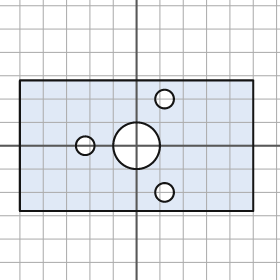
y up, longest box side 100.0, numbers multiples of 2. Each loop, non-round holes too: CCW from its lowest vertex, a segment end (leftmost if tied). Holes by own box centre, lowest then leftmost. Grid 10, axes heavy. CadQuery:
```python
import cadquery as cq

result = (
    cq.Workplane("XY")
    .moveTo(-50.0, -28.0)
    .lineTo(50.0, -28.0)
    .lineTo(50.0, 28.0)
    .lineTo(-50.0, 28.0)
    .close()
    .moveTo(12.0, -20.0)
    .circle(4.0)
    .moveTo(-22.0, 0.0)
    .circle(4.0)
    .moveTo(0.0, 0.0)
    .circle(10.0)
    .moveTo(12.0, 20.0)
    .circle(4.0)
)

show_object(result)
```